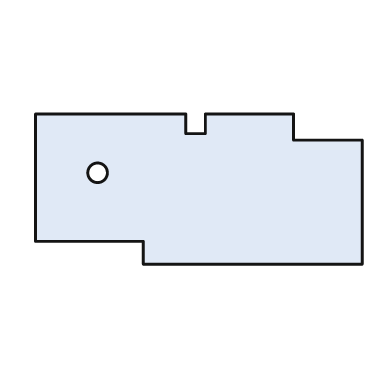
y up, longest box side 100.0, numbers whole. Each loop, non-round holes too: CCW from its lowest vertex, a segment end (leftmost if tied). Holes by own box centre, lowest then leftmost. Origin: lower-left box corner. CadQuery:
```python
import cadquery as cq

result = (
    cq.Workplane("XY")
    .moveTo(33.0, 0.0)
    .lineTo(100.0, 0.0)
    .lineTo(100.0, 38.0)
    .lineTo(79.0, 38.0)
    .lineTo(79.0, 46.0)
    .lineTo(52.0, 46.0)
    .lineTo(52.0, 40.0)
    .lineTo(46.0, 40.0)
    .lineTo(46.0, 46.0)
    .lineTo(0.0, 46.0)
    .lineTo(0.0, 7.0)
    .lineTo(33.0, 7.0)
    .close()
    .moveTo(19.0, 28.0)
    .circle(3.0)
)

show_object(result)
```